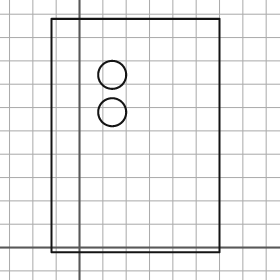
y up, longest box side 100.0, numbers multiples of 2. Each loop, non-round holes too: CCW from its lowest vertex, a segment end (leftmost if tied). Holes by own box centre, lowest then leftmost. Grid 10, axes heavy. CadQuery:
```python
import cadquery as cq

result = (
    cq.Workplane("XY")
    .moveTo(-12.0, -2.0)
    .lineTo(60.0, -2.0)
    .lineTo(60.0, 98.0)
    .lineTo(-12.0, 98.0)
    .close()
    .moveTo(14.0, 58.0)
    .circle(6.0)
    .moveTo(14.0, 74.0)
    .circle(6.0)
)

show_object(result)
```